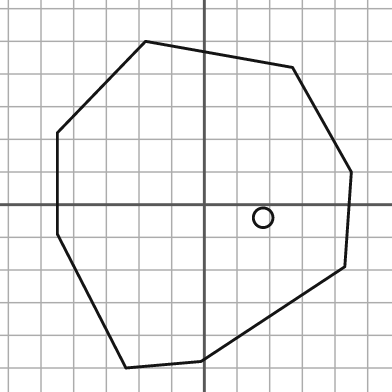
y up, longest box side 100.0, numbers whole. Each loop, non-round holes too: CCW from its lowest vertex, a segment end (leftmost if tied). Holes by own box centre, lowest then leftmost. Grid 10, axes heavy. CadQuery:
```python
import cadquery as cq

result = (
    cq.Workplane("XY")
    .moveTo(-24.0, -50.0)
    .lineTo(-1.0, -48.0)
    .lineTo(43.0, -19.0)
    .lineTo(45.0, 10.0)
    .lineTo(27.0, 42.0)
    .lineTo(-18.0, 50.0)
    .lineTo(-45.0, 22.0)
    .lineTo(-45.0, -9.0)
    .close()
    .moveTo(18.0, -4.0)
    .circle(3.0)
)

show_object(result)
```